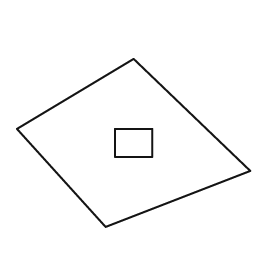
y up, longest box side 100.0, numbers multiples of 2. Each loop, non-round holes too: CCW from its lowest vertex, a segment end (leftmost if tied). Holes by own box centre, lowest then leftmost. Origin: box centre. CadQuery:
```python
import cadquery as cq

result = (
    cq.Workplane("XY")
    .moveTo(-12.0, -36.0)
    .lineTo(50.0, -12.0)
    .lineTo(0.0, 36.0)
    .lineTo(-50.0, 6.0)
    .close()
    .moveTo(-8.0, -6.0)
    .lineTo(8.0, -6.0)
    .lineTo(8.0, 6.0)
    .lineTo(-8.0, 6.0)
    .close()
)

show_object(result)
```